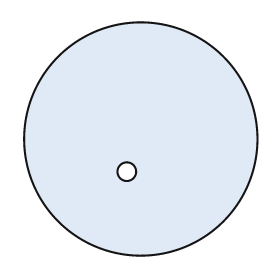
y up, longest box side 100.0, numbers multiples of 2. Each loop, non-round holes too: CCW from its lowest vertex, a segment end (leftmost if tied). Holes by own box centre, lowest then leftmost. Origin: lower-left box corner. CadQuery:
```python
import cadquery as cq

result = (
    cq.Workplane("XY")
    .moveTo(50.0, 50.0)
    .circle(50.0)
    .moveTo(44.0, 36.0)
    .circle(4.0)
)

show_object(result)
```